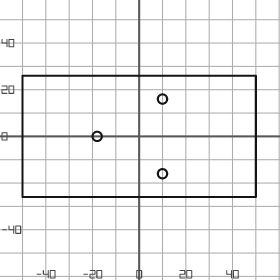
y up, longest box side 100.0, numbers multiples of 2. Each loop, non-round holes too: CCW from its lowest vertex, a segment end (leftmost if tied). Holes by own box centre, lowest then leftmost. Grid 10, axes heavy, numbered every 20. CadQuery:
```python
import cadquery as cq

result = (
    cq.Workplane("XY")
    .moveTo(-50.0, -26.0)
    .lineTo(50.0, -26.0)
    .lineTo(50.0, 26.0)
    .lineTo(-50.0, 26.0)
    .close()
    .moveTo(10.0, -16.0)
    .circle(2.0)
    .moveTo(-18.0, 0.0)
    .circle(2.0)
    .moveTo(10.0, 16.0)
    .circle(2.0)
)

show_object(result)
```